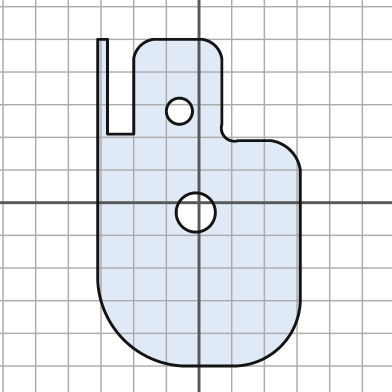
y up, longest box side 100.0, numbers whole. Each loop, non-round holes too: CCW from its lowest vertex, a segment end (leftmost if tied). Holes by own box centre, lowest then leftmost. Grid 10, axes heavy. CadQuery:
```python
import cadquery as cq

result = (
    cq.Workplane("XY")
    .moveTo(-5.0, -50.0)
    .lineTo(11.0, -50.0)
    .threePointArc((25.0, -44.0), (31.0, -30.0))
    .lineTo(31.0, 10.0)
    .threePointArc((28.0, 16.0), (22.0, 19.0))
    .lineTo(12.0, 19.0)
    .threePointArc((8.0, 20.0), (7.0, 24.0))
    .lineTo(7.0, 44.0)
    .threePointArc((5.0, 48.0), (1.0, 50.0))
    .lineTo(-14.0, 50.0)
    .threePointArc((-18.0, 48.0), (-20.0, 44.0))
    .lineTo(-20.0, 21.0)
    .lineTo(-28.0, 21.0)
    .lineTo(-28.0, 50.0)
    .lineTo(-31.0, 50.0)
    .lineTo(-31.0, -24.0)
    .threePointArc((-23.0, -42.0), (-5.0, -50.0))
    .close()
    .moveTo(-1.0, -3.0)
    .circle(6.0)
    .moveTo(-6.0, 28.0)
    .circle(4.0)
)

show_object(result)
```